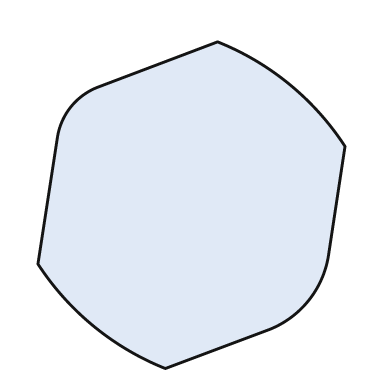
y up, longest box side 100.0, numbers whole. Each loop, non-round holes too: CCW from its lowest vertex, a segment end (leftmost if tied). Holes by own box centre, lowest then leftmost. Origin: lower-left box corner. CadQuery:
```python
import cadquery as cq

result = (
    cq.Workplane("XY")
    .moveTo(39.0, 0.0)
    .lineTo(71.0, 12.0)
    .threePointArc((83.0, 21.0), (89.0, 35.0))
    .lineTo(94.0, 68.0)
    .threePointArc((77.0, 87.0), (55.0, 100.0))
    .lineTo(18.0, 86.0)
    .threePointArc((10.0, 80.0), (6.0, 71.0))
    .lineTo(0.0, 32.0)
    .threePointArc((17.0, 13.0), (39.0, 0.0))
    .close()
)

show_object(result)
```